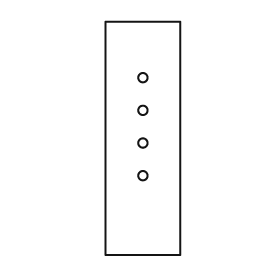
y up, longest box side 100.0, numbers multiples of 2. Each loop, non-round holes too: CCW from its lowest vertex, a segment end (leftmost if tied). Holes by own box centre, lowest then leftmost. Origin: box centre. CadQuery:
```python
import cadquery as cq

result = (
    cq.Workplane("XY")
    .moveTo(-16.0, -50.0)
    .lineTo(16.0, -50.0)
    .lineTo(16.0, 50.0)
    .lineTo(-16.0, 50.0)
    .close()
    .moveTo(0.0, -16.0)
    .circle(2.0)
    .moveTo(0.0, -2.0)
    .circle(2.0)
    .moveTo(0.0, 12.0)
    .circle(2.0)
    .moveTo(0.0, 26.0)
    .circle(2.0)
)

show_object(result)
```